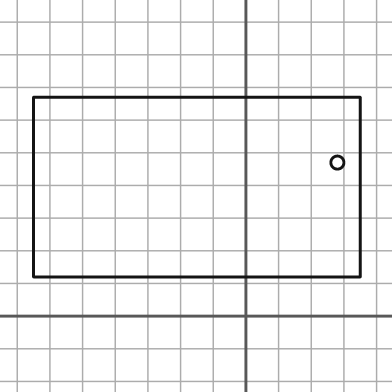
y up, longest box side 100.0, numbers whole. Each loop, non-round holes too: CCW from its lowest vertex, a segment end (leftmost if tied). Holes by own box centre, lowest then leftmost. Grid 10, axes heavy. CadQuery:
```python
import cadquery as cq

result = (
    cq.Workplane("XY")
    .moveTo(-65.0, 12.0)
    .lineTo(35.0, 12.0)
    .lineTo(35.0, 67.0)
    .lineTo(-65.0, 67.0)
    .close()
    .moveTo(28.0, 47.0)
    .circle(2.0)
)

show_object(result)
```